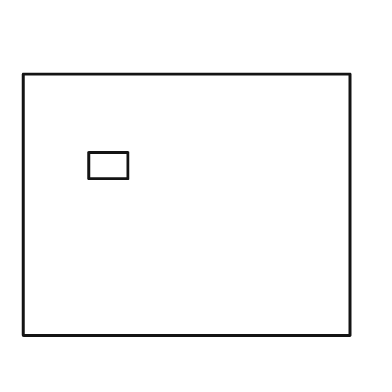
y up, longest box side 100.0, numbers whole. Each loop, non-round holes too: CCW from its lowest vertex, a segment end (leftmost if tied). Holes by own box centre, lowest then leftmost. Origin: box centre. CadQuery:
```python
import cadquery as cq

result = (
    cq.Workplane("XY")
    .moveTo(-50.0, -40.0)
    .lineTo(50.0, -40.0)
    .lineTo(50.0, 40.0)
    .lineTo(-50.0, 40.0)
    .close()
    .moveTo(-30.0, 8.0)
    .lineTo(-18.0, 8.0)
    .lineTo(-18.0, 16.0)
    .lineTo(-30.0, 16.0)
    .close()
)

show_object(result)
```